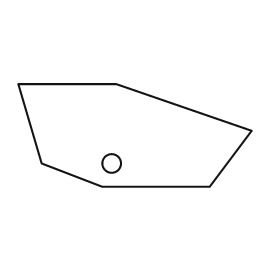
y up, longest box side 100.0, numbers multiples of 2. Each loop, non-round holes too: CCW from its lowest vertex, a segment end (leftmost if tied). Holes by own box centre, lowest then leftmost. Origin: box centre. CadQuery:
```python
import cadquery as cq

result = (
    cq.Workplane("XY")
    .moveTo(-14.0, -22.0)
    .lineTo(32.0, -22.0)
    .lineTo(50.0, 2.0)
    .lineTo(-8.0, 22.0)
    .lineTo(-50.0, 22.0)
    .lineTo(-40.0, -12.0)
    .close()
    .moveTo(-10.0, -12.0)
    .circle(4.0)
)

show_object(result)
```